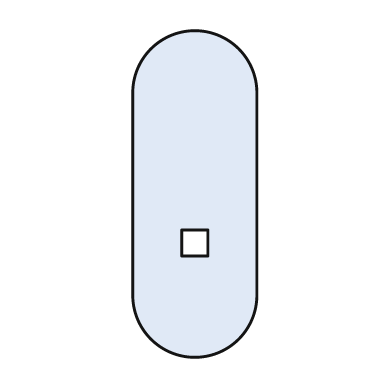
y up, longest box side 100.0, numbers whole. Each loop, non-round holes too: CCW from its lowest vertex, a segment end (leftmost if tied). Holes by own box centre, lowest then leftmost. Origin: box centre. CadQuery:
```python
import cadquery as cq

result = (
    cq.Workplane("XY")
    .moveTo(-19.0, -31.0)
    .threePointArc((0.0, -50.0), (19.0, -31.0))
    .lineTo(19.0, 31.0)
    .threePointArc((0.0, 50.0), (-19.0, 31.0))
    .close()
    .moveTo(-4.0, -19.0)
    .lineTo(4.0, -19.0)
    .lineTo(4.0, -11.0)
    .lineTo(-4.0, -11.0)
    .close()
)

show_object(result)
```